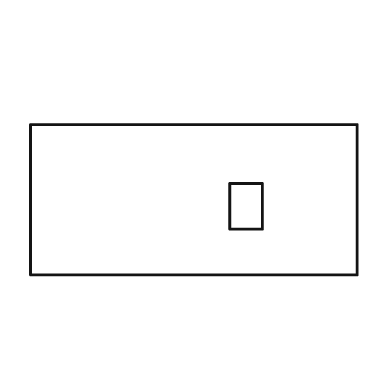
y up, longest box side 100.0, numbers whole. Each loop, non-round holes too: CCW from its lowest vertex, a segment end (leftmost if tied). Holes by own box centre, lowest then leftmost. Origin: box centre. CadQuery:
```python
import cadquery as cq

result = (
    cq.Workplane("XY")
    .moveTo(-50.0, -23.0)
    .lineTo(50.0, -23.0)
    .lineTo(50.0, 23.0)
    .lineTo(-50.0, 23.0)
    .close()
    .moveTo(11.0, -9.0)
    .lineTo(21.0, -9.0)
    .lineTo(21.0, 5.0)
    .lineTo(11.0, 5.0)
    .close()
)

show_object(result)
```